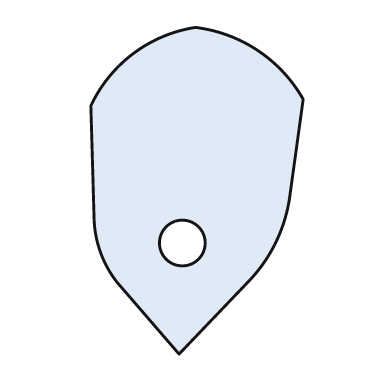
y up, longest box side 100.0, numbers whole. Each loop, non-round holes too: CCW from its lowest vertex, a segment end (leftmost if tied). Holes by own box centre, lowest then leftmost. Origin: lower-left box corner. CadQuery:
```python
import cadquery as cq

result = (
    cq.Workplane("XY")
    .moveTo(27.0, 0.0)
    .lineTo(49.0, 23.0)
    .threePointArc((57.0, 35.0), (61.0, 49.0))
    .lineTo(65.0, 78.0)
    .threePointArc((51.0, 93.0), (32.0, 100.0))
    .threePointArc((13.0, 92.0), (0.0, 76.0))
    .lineTo(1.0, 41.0)
    .threePointArc((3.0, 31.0), (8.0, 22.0))
    .close()
    .moveTo(28.0, 34.0)
    .circle(7.0)
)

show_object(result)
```